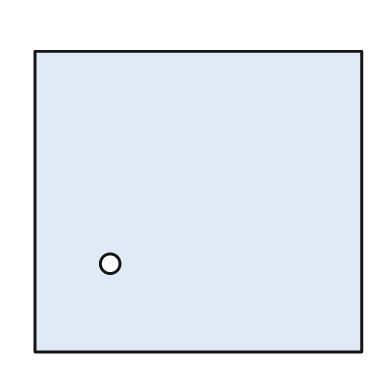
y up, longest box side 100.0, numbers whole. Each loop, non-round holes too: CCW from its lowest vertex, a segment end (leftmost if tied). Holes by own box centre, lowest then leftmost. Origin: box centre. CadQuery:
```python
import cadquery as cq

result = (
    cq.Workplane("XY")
    .moveTo(-50.0, -46.0)
    .lineTo(50.0, -46.0)
    .lineTo(50.0, 46.0)
    .lineTo(-50.0, 46.0)
    .close()
    .moveTo(-27.0, -19.0)
    .circle(3.0)
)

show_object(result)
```